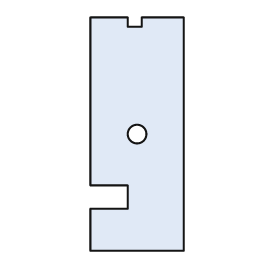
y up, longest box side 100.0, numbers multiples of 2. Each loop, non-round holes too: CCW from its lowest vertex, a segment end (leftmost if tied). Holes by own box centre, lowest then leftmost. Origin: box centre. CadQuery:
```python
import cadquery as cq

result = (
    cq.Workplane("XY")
    .moveTo(-20.0, -50.0)
    .lineTo(20.0, -50.0)
    .lineTo(20.0, 50.0)
    .lineTo(2.0, 50.0)
    .lineTo(2.0, 46.0)
    .lineTo(-4.0, 46.0)
    .lineTo(-4.0, 50.0)
    .lineTo(-20.0, 50.0)
    .lineTo(-20.0, -22.0)
    .lineTo(-4.0, -22.0)
    .lineTo(-4.0, -32.0)
    .lineTo(-20.0, -32.0)
    .close()
    .moveTo(0.0, 0.0)
    .circle(4.0)
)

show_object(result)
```